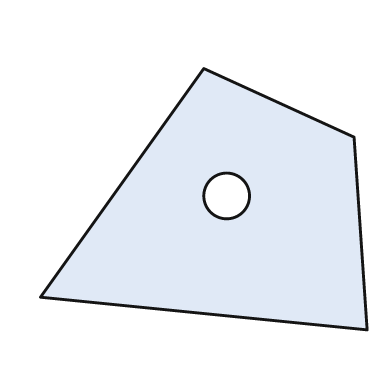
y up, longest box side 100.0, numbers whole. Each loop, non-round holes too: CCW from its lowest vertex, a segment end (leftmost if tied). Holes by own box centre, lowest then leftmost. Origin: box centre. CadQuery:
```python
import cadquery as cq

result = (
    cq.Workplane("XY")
    .moveTo(50.0, -40.0)
    .lineTo(46.0, 19.0)
    .lineTo(0.0, 40.0)
    .lineTo(-50.0, -30.0)
    .close()
    .moveTo(7.0, 1.0)
    .circle(7.0)
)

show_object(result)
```